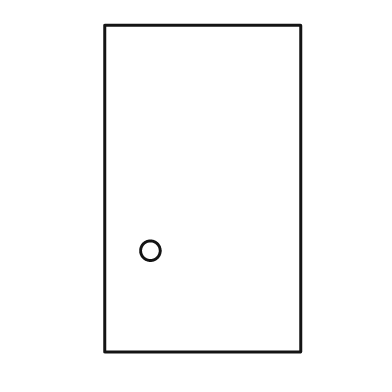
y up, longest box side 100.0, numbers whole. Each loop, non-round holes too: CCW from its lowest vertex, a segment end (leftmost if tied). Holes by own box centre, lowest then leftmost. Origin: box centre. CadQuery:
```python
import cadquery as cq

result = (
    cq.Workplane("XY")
    .moveTo(-30.0, -50.0)
    .lineTo(30.0, -50.0)
    .lineTo(30.0, 50.0)
    .lineTo(-30.0, 50.0)
    .close()
    .moveTo(-16.0, -19.0)
    .circle(3.0)
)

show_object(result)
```